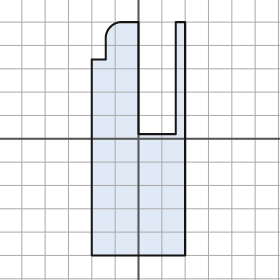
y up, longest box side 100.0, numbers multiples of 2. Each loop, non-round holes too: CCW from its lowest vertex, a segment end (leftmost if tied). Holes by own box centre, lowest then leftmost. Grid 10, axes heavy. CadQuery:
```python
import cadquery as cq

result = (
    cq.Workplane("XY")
    .moveTo(-20.0, -50.0)
    .lineTo(20.0, -50.0)
    .lineTo(20.0, 50.0)
    .lineTo(16.0, 50.0)
    .lineTo(16.0, 2.0)
    .lineTo(0.0, 2.0)
    .lineTo(0.0, 50.0)
    .lineTo(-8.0, 50.0)
    .threePointArc((-12.0, 48.0), (-14.0, 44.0))
    .lineTo(-14.0, 34.0)
    .lineTo(-20.0, 34.0)
    .close()
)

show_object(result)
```